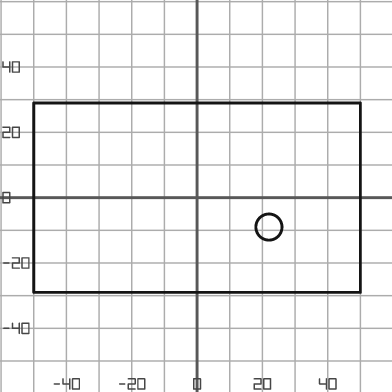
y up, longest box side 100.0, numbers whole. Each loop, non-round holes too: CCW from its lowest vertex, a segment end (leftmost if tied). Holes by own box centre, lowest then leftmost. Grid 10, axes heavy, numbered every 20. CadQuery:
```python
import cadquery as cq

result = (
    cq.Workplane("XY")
    .moveTo(-50.0, -29.0)
    .lineTo(50.0, -29.0)
    .lineTo(50.0, 29.0)
    .lineTo(-50.0, 29.0)
    .close()
    .moveTo(22.0, -9.0)
    .circle(4.0)
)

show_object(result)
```